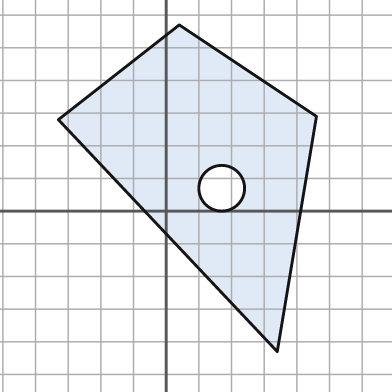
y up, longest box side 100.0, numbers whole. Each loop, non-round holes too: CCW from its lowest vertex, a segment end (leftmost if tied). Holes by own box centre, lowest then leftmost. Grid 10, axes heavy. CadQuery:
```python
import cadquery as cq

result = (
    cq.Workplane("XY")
    .moveTo(34.0, -43.0)
    .lineTo(46.0, 29.0)
    .lineTo(4.0, 57.0)
    .lineTo(-33.0, 28.0)
    .close()
    .moveTo(17.0, 7.0)
    .circle(7.0)
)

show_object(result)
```